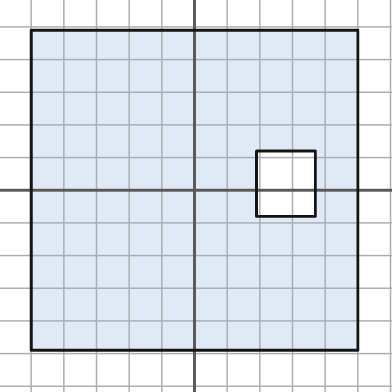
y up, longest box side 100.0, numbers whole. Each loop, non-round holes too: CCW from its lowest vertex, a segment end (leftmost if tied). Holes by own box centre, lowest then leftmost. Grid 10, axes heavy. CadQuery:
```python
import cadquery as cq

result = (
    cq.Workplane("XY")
    .moveTo(-50.0, -49.0)
    .lineTo(50.0, -49.0)
    .lineTo(50.0, 49.0)
    .lineTo(-50.0, 49.0)
    .close()
    .moveTo(19.0, -8.0)
    .lineTo(37.0, -8.0)
    .lineTo(37.0, 12.0)
    .lineTo(19.0, 12.0)
    .close()
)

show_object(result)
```